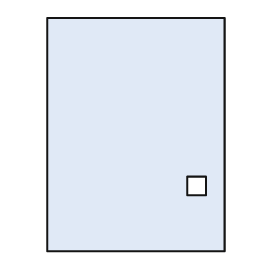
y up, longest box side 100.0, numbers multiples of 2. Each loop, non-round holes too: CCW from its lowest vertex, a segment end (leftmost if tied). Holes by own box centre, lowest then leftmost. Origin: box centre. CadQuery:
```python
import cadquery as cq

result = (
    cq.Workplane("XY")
    .moveTo(-38.0, -50.0)
    .lineTo(38.0, -50.0)
    .lineTo(38.0, 50.0)
    .lineTo(-38.0, 50.0)
    .close()
    .moveTo(22.0, -26.0)
    .lineTo(30.0, -26.0)
    .lineTo(30.0, -18.0)
    .lineTo(22.0, -18.0)
    .close()
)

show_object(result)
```